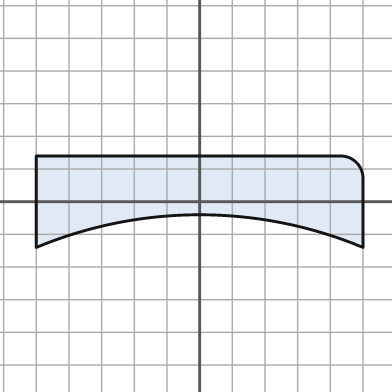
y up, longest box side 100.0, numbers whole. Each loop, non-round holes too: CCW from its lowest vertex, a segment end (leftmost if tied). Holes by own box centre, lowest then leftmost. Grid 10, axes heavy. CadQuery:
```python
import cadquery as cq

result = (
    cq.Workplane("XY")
    .moveTo(-50.0, -14.0)
    .threePointArc((0.0, -4.0), (50.0, -14.0))
    .lineTo(50.0, 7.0)
    .threePointArc((48.0, 12.0), (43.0, 14.0))
    .lineTo(-50.0, 14.0)
    .close()
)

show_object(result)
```